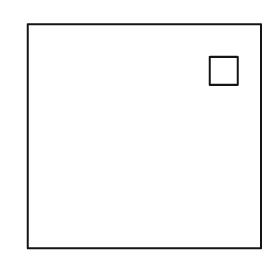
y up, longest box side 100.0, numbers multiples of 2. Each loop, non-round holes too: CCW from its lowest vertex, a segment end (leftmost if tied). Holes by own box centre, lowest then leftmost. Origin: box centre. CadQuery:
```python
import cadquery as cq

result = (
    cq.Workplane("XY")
    .moveTo(-50.0, -48.0)
    .lineTo(50.0, -48.0)
    .lineTo(50.0, 48.0)
    .lineTo(-50.0, 48.0)
    .close()
    .moveTo(28.0, 22.0)
    .lineTo(40.0, 22.0)
    .lineTo(40.0, 34.0)
    .lineTo(28.0, 34.0)
    .close()
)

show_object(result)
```